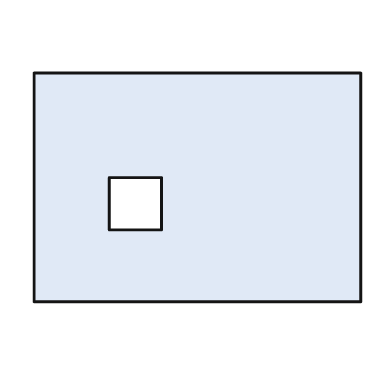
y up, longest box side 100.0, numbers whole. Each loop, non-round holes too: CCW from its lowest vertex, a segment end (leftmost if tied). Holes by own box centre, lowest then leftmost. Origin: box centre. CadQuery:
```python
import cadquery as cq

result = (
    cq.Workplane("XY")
    .moveTo(-50.0, -35.0)
    .lineTo(50.0, -35.0)
    .lineTo(50.0, 35.0)
    .lineTo(-50.0, 35.0)
    .close()
    .moveTo(-27.0, -13.0)
    .lineTo(-11.0, -13.0)
    .lineTo(-11.0, 3.0)
    .lineTo(-27.0, 3.0)
    .close()
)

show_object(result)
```